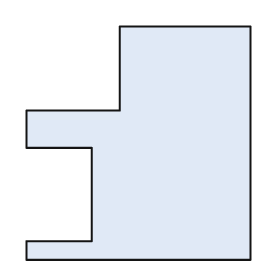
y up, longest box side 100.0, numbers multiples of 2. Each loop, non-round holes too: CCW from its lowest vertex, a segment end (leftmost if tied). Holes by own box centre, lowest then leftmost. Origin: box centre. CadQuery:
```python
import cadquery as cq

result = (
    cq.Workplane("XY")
    .moveTo(-48.0, -50.0)
    .lineTo(48.0, -50.0)
    .lineTo(48.0, 50.0)
    .lineTo(-8.0, 50.0)
    .lineTo(-8.0, 14.0)
    .lineTo(-48.0, 14.0)
    .lineTo(-48.0, -2.0)
    .lineTo(-20.0, -2.0)
    .lineTo(-20.0, -42.0)
    .lineTo(-48.0, -42.0)
    .close()
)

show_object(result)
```